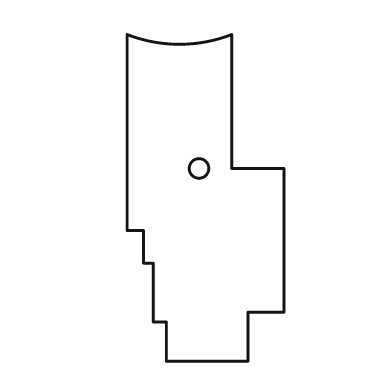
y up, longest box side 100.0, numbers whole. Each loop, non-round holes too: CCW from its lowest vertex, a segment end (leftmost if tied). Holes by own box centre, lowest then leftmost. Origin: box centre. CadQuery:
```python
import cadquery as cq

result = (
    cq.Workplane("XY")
    .moveTo(-12.0, -50.0)
    .lineTo(13.0, -50.0)
    .lineTo(13.0, -35.0)
    .lineTo(24.0, -35.0)
    .lineTo(24.0, 9.0)
    .lineTo(8.0, 9.0)
    .lineTo(8.0, 50.0)
    .threePointArc((-8.0, 47.0), (-24.0, 50.0))
    .lineTo(-24.0, -10.0)
    .lineTo(-19.0, -10.0)
    .lineTo(-19.0, -20.0)
    .lineTo(-16.0, -20.0)
    .lineTo(-16.0, -38.0)
    .lineTo(-12.0, -38.0)
    .close()
    .moveTo(-2.0, 9.0)
    .circle(3.0)
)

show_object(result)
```